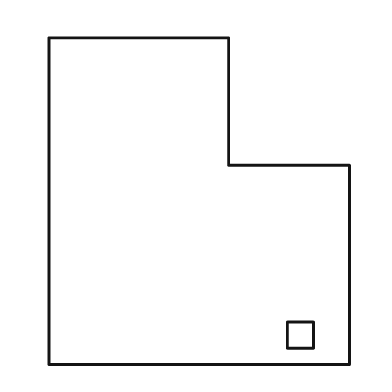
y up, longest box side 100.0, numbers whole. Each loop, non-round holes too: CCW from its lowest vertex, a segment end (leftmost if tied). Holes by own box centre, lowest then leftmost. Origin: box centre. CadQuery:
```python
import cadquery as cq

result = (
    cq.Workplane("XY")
    .moveTo(-46.0, -50.0)
    .lineTo(46.0, -50.0)
    .lineTo(46.0, 11.0)
    .lineTo(9.0, 11.0)
    .lineTo(9.0, 50.0)
    .lineTo(-46.0, 50.0)
    .close()
    .moveTo(27.0, -45.0)
    .lineTo(35.0, -45.0)
    .lineTo(35.0, -37.0)
    .lineTo(27.0, -37.0)
    .close()
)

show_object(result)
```